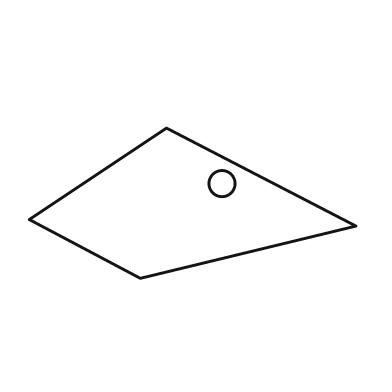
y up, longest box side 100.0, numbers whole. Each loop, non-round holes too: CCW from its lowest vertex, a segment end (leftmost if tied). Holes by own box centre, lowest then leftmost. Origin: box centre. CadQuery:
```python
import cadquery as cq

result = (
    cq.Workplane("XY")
    .moveTo(-16.0, -23.0)
    .lineTo(50.0, -7.0)
    .lineTo(-8.0, 23.0)
    .lineTo(-50.0, -5.0)
    .close()
    .moveTo(9.0, 6.0)
    .circle(4.0)
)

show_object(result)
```